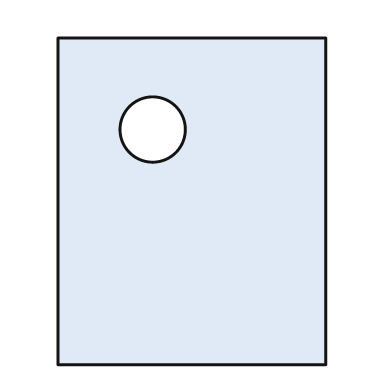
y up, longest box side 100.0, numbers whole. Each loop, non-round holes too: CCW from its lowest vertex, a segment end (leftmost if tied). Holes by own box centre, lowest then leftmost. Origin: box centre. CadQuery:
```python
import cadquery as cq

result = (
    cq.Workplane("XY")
    .moveTo(-41.0, -50.0)
    .lineTo(41.0, -50.0)
    .lineTo(41.0, 50.0)
    .lineTo(-41.0, 50.0)
    .close()
    .moveTo(-12.0, 22.0)
    .circle(10.0)
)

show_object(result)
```